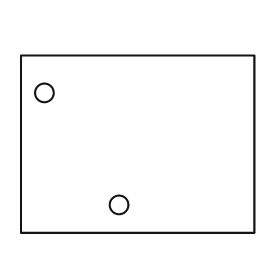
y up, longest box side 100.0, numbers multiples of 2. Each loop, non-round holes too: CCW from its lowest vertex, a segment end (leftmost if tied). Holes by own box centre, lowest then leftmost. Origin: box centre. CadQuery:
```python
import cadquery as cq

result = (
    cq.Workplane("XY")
    .moveTo(-50.0, -38.0)
    .lineTo(50.0, -38.0)
    .lineTo(50.0, 38.0)
    .lineTo(-50.0, 38.0)
    .close()
    .moveTo(-8.0, -26.0)
    .circle(4.0)
    .moveTo(-40.0, 22.0)
    .circle(4.0)
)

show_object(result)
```